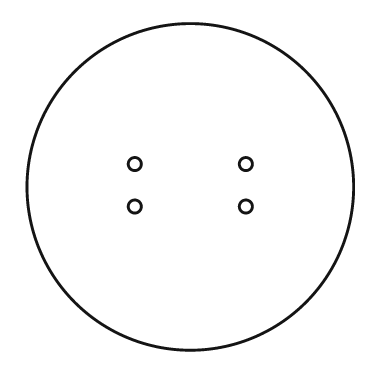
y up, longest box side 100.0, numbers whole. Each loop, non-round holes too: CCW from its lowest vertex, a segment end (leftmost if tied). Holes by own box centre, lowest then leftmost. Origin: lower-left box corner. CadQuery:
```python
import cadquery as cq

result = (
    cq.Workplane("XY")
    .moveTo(50.0, 50.0)
    .circle(50.0)
    .moveTo(33.0, 44.0)
    .circle(2.0)
    .moveTo(67.0, 44.0)
    .circle(2.0)
    .moveTo(33.0, 57.0)
    .circle(2.0)
    .moveTo(67.0, 57.0)
    .circle(2.0)
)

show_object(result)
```